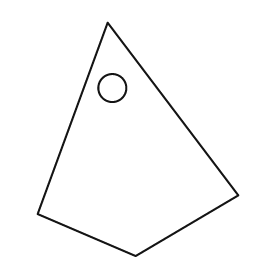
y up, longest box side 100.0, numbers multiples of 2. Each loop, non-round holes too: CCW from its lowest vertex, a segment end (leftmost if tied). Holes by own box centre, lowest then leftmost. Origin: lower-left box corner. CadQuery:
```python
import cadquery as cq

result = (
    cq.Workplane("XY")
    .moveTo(42.0, 0.0)
    .lineTo(86.0, 26.0)
    .lineTo(30.0, 100.0)
    .lineTo(0.0, 18.0)
    .close()
    .moveTo(32.0, 72.0)
    .circle(6.0)
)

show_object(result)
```